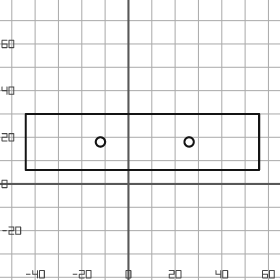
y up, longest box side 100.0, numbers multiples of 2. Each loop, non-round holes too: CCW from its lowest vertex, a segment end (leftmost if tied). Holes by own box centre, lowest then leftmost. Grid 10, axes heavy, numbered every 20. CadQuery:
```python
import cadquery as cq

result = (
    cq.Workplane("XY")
    .moveTo(-44.0, 6.0)
    .lineTo(56.0, 6.0)
    .lineTo(56.0, 30.0)
    .lineTo(-44.0, 30.0)
    .close()
    .moveTo(-12.0, 18.0)
    .circle(2.0)
    .moveTo(26.0, 18.0)
    .circle(2.0)
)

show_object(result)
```